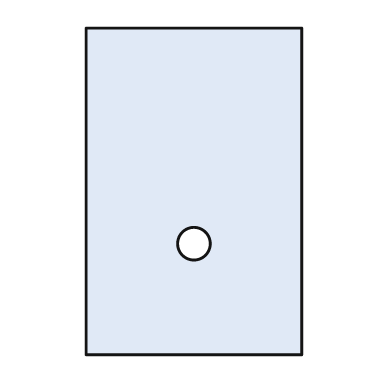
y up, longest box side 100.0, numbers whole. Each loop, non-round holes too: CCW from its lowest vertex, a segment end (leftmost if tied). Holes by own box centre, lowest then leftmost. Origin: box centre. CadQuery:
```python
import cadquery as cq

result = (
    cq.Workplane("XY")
    .moveTo(-33.0, -50.0)
    .lineTo(33.0, -50.0)
    .lineTo(33.0, 50.0)
    .lineTo(-33.0, 50.0)
    .close()
    .moveTo(0.0, -16.0)
    .circle(5.0)
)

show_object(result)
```